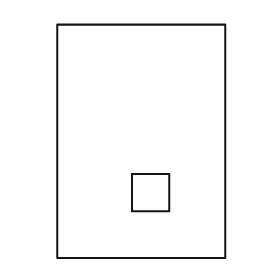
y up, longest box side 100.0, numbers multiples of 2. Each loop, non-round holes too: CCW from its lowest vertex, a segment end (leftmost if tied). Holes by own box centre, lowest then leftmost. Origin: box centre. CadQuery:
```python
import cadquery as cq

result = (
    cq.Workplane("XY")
    .moveTo(-36.0, -50.0)
    .lineTo(36.0, -50.0)
    .lineTo(36.0, 50.0)
    .lineTo(-36.0, 50.0)
    .close()
    .moveTo(-4.0, -30.0)
    .lineTo(12.0, -30.0)
    .lineTo(12.0, -14.0)
    .lineTo(-4.0, -14.0)
    .close()
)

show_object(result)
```